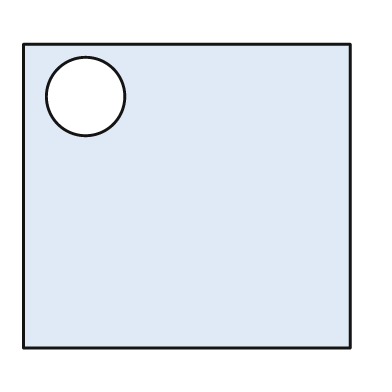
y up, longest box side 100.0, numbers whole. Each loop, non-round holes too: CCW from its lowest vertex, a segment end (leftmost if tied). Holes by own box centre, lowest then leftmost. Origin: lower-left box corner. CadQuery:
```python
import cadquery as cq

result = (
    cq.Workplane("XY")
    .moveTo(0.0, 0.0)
    .lineTo(100.0, 0.0)
    .lineTo(100.0, 93.0)
    .lineTo(0.0, 93.0)
    .close()
    .moveTo(19.0, 77.0)
    .circle(12.0)
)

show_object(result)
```